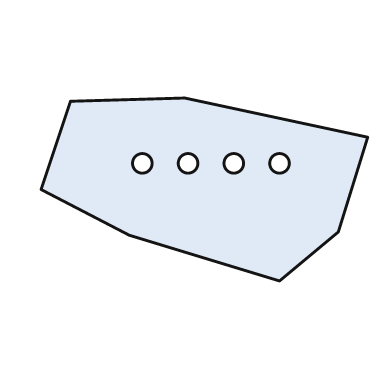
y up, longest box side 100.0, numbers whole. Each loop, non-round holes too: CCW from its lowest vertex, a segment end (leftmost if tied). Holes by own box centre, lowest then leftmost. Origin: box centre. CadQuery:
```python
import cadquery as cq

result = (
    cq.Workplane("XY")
    .moveTo(23.0, -28.0)
    .lineTo(41.0, -13.0)
    .lineTo(50.0, 16.0)
    .lineTo(-6.0, 28.0)
    .lineTo(-41.0, 27.0)
    .lineTo(-50.0, 0.0)
    .lineTo(-23.0, -14.0)
    .close()
    .moveTo(-19.0, 8.0)
    .circle(3.0)
    .moveTo(-5.0, 8.0)
    .circle(3.0)
    .moveTo(9.0, 8.0)
    .circle(3.0)
    .moveTo(23.0, 8.0)
    .circle(3.0)
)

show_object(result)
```